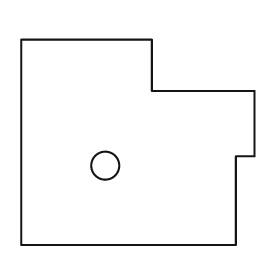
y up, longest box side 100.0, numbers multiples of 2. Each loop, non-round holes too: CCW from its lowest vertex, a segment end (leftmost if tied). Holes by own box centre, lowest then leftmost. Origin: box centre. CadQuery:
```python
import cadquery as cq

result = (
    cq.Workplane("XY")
    .moveTo(-50.0, -44.0)
    .lineTo(42.0, -44.0)
    .lineTo(42.0, -6.0)
    .lineTo(50.0, -6.0)
    .lineTo(50.0, 22.0)
    .lineTo(6.0, 22.0)
    .lineTo(6.0, 44.0)
    .lineTo(-50.0, 44.0)
    .close()
    .moveTo(-14.0, -10.0)
    .circle(6.0)
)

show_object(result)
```